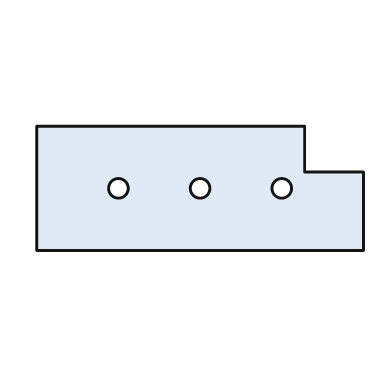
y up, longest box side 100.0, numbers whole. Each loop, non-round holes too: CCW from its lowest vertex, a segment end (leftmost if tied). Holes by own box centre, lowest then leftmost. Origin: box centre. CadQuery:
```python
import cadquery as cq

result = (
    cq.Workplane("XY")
    .moveTo(-50.0, -19.0)
    .lineTo(50.0, -19.0)
    .lineTo(50.0, 5.0)
    .lineTo(32.0, 5.0)
    .lineTo(32.0, 19.0)
    .lineTo(-50.0, 19.0)
    .close()
    .moveTo(-25.0, 0.0)
    .circle(3.0)
    .moveTo(0.0, 0.0)
    .circle(3.0)
    .moveTo(25.0, 0.0)
    .circle(3.0)
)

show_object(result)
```